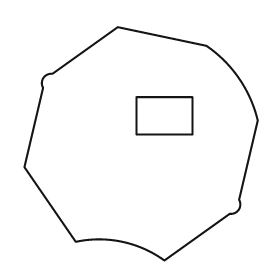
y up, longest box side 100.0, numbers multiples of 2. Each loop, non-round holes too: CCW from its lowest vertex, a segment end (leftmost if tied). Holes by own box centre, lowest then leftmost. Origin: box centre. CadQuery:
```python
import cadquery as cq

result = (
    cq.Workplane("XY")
    .moveTo(10.0, -50.0)
    .lineTo(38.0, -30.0)
    .threePointArc((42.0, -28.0), (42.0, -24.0))
    .lineTo(50.0, 10.0)
    .threePointArc((42.0, 28.0), (28.0, 42.0))
    .lineTo(-10.0, 50.0)
    .lineTo(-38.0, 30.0)
    .threePointArc((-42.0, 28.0), (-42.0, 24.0))
    .lineTo(-50.0, -10.0)
    .lineTo(-28.0, -42.0)
    .threePointArc((-8.0, -42.0), (10.0, -50.0))
    .close()
    .moveTo(-2.0, 4.0)
    .lineTo(22.0, 4.0)
    .lineTo(22.0, 20.0)
    .lineTo(-2.0, 20.0)
    .close()
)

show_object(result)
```